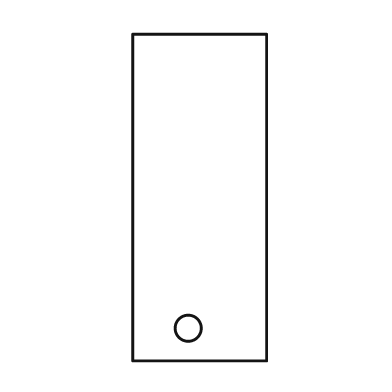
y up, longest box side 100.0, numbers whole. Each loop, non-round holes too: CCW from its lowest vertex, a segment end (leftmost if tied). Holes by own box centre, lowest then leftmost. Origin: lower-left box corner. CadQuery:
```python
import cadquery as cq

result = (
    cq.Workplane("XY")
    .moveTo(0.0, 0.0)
    .lineTo(41.0, 0.0)
    .lineTo(41.0, 100.0)
    .lineTo(0.0, 100.0)
    .close()
    .moveTo(17.0, 10.0)
    .circle(4.0)
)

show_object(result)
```